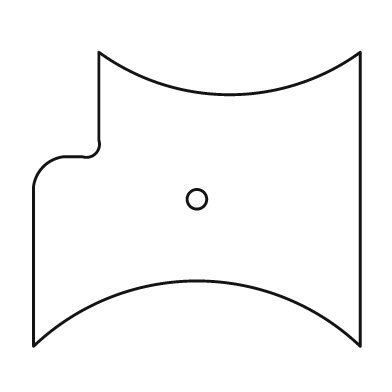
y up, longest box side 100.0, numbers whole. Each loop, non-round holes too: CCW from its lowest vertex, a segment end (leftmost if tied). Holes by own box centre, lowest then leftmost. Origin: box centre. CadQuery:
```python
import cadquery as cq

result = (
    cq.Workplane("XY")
    .moveTo(-50.0, -45.0)
    .threePointArc((0.0, -25.0), (50.0, -45.0))
    .lineTo(50.0, 45.0)
    .threePointArc((10.0, 32.0), (-30.0, 45.0))
    .lineTo(-30.0, 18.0)
    .threePointArc((-31.0, 14.0), (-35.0, 13.0))
    .lineTo(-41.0, 13.0)
    .threePointArc((-47.0, 10.0), (-50.0, 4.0))
    .close()
    .moveTo(0.0, 0.0)
    .circle(3.0)
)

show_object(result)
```